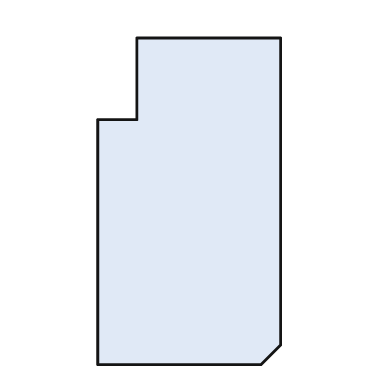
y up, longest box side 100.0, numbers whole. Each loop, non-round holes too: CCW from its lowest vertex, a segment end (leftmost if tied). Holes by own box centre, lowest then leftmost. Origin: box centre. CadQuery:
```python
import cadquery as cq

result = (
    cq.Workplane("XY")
    .moveTo(-28.0, -50.0)
    .lineTo(22.0, -50.0)
    .lineTo(28.0, -44.0)
    .lineTo(28.0, 50.0)
    .lineTo(-16.0, 50.0)
    .lineTo(-16.0, 25.0)
    .lineTo(-28.0, 25.0)
    .close()
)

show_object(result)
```